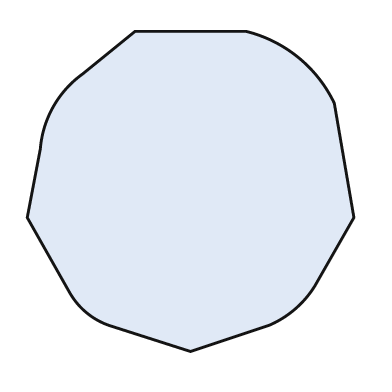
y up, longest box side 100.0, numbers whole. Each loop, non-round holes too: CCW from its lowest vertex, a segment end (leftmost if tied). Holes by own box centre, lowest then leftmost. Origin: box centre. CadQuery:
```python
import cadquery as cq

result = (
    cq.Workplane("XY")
    .moveTo(0.0, -49.0)
    .lineTo(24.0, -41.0)
    .threePointArc((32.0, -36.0), (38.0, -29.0))
    .lineTo(50.0, -8.0)
    .lineTo(44.0, 27.0)
    .threePointArc((33.0, 41.0), (17.0, 49.0))
    .lineTo(-17.0, 49.0)
    .lineTo(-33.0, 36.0)
    .threePointArc((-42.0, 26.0), (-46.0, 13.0))
    .lineTo(-50.0, -8.0)
    .lineTo(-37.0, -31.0)
    .threePointArc((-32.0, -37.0), (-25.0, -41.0))
    .close()
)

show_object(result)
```